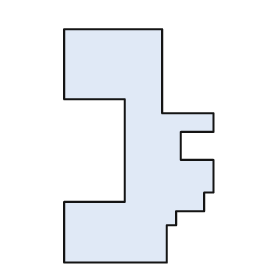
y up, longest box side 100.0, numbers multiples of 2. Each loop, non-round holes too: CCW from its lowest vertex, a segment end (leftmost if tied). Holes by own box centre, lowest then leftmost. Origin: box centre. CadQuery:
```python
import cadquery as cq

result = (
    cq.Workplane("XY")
    .moveTo(-32.0, -50.0)
    .lineTo(12.0, -50.0)
    .lineTo(12.0, -34.0)
    .lineTo(16.0, -34.0)
    .lineTo(16.0, -28.0)
    .lineTo(28.0, -28.0)
    .lineTo(28.0, -20.0)
    .lineTo(32.0, -20.0)
    .lineTo(32.0, -6.0)
    .lineTo(18.0, -6.0)
    .lineTo(18.0, 6.0)
    .lineTo(32.0, 6.0)
    .lineTo(32.0, 14.0)
    .lineTo(10.0, 14.0)
    .lineTo(10.0, 50.0)
    .lineTo(-32.0, 50.0)
    .lineTo(-32.0, 20.0)
    .lineTo(-6.0, 20.0)
    .lineTo(-6.0, -24.0)
    .lineTo(-32.0, -24.0)
    .close()
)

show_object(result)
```